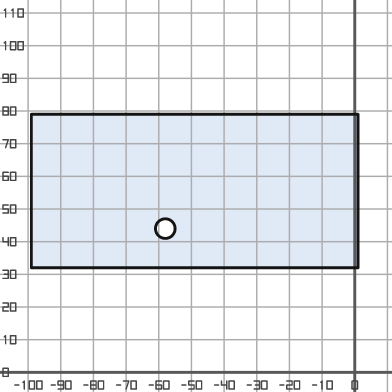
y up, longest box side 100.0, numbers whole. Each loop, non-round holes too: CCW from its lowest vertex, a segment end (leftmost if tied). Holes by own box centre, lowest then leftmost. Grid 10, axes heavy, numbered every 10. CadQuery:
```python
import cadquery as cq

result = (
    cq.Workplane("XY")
    .moveTo(-99.0, 32.0)
    .lineTo(1.0, 32.0)
    .lineTo(1.0, 79.0)
    .lineTo(-99.0, 79.0)
    .close()
    .moveTo(-58.0, 44.0)
    .circle(3.0)
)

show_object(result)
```